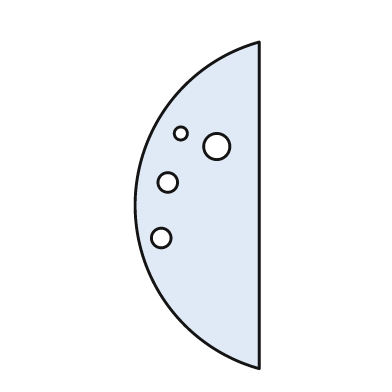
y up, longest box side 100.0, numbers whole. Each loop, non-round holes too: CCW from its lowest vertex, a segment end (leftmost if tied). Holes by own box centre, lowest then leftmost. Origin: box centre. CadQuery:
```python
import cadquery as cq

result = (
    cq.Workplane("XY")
    .moveTo(19.0, -50.0)
    .lineTo(19.0, 50.0)
    .threePointArc((-19.0, 0.0), (19.0, -50.0))
    .close()
    .moveTo(-11.0, -10.0)
    .circle(3.0)
    .moveTo(-9.0, 7.0)
    .circle(3.0)
    .moveTo(6.0, 18.0)
    .circle(4.0)
    .moveTo(-5.0, 22.0)
    .circle(2.0)
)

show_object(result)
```